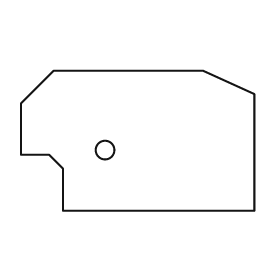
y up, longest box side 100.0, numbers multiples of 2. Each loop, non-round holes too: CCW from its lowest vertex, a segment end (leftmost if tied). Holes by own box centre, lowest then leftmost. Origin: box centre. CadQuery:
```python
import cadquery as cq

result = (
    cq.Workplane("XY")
    .moveTo(-32.0, -30.0)
    .lineTo(50.0, -30.0)
    .lineTo(50.0, 20.0)
    .lineTo(28.0, 30.0)
    .lineTo(-36.0, 30.0)
    .lineTo(-50.0, 16.0)
    .lineTo(-50.0, -6.0)
    .lineTo(-38.0, -6.0)
    .lineTo(-32.0, -12.0)
    .close()
    .moveTo(-14.0, -4.0)
    .circle(4.0)
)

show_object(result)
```